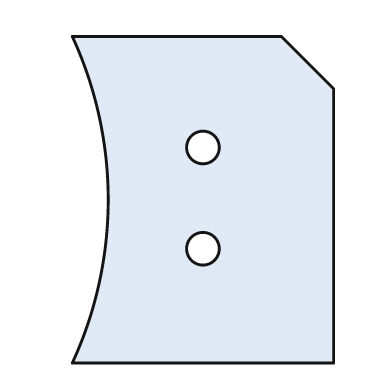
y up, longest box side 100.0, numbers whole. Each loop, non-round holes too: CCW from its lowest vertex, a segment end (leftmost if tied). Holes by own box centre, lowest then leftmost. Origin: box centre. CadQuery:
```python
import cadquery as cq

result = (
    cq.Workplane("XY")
    .moveTo(-40.0, -50.0)
    .lineTo(40.0, -50.0)
    .lineTo(40.0, 34.0)
    .lineTo(24.0, 50.0)
    .lineTo(-40.0, 50.0)
    .threePointArc((-29.0, 0.0), (-40.0, -50.0))
    .close()
    .moveTo(0.0, -15.0)
    .circle(5.0)
    .moveTo(0.0, 16.0)
    .circle(5.0)
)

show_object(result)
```